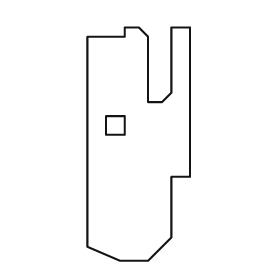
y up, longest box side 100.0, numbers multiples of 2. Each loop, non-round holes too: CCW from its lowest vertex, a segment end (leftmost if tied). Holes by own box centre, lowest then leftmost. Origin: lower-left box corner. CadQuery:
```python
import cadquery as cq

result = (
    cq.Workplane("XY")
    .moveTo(14.0, 0.0)
    .lineTo(26.0, 0.0)
    .lineTo(36.0, 10.0)
    .lineTo(36.0, 36.0)
    .lineTo(44.0, 36.0)
    .lineTo(44.0, 100.0)
    .lineTo(36.0, 100.0)
    .lineTo(36.0, 72.0)
    .lineTo(32.0, 68.0)
    .lineTo(26.0, 68.0)
    .lineTo(26.0, 96.0)
    .lineTo(22.0, 100.0)
    .lineTo(16.0, 100.0)
    .lineTo(16.0, 96.0)
    .lineTo(0.0, 96.0)
    .lineTo(0.0, 6.0)
    .close()
    .moveTo(8.0, 54.0)
    .lineTo(16.0, 54.0)
    .lineTo(16.0, 62.0)
    .lineTo(8.0, 62.0)
    .close()
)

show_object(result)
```